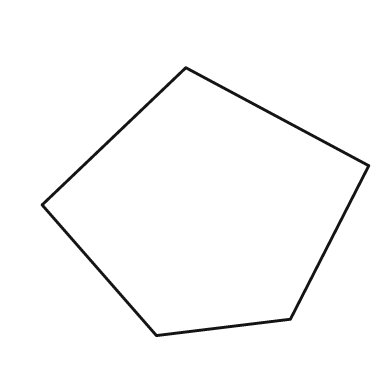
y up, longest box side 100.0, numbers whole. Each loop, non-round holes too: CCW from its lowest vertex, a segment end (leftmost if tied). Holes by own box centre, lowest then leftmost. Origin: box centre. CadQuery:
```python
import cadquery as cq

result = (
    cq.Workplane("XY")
    .moveTo(-15.0, -41.0)
    .lineTo(26.0, -36.0)
    .lineTo(50.0, 11.0)
    .lineTo(-6.0, 41.0)
    .lineTo(-50.0, -1.0)
    .close()
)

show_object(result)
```